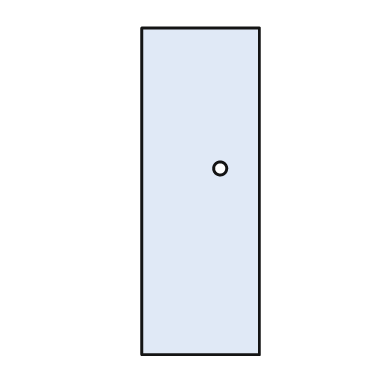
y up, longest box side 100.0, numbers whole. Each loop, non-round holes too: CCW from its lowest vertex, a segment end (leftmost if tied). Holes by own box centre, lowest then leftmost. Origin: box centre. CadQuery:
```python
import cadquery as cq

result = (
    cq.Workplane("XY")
    .moveTo(-18.0, -50.0)
    .lineTo(18.0, -50.0)
    .lineTo(18.0, 50.0)
    .lineTo(-18.0, 50.0)
    .close()
    .moveTo(6.0, 7.0)
    .circle(2.0)
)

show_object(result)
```